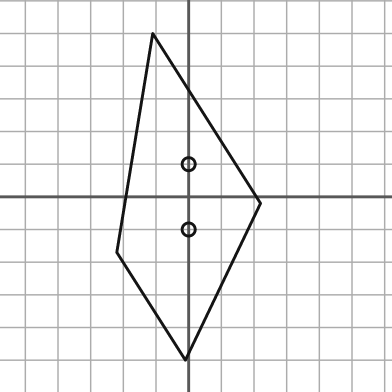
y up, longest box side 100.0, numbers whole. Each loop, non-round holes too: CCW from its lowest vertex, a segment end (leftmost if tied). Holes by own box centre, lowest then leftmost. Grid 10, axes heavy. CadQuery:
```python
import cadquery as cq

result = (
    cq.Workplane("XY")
    .moveTo(-1.0, -50.0)
    .lineTo(22.0, -2.0)
    .lineTo(-11.0, 50.0)
    .lineTo(-22.0, -17.0)
    .close()
    .moveTo(0.0, -10.0)
    .circle(2.0)
    .moveTo(0.0, 10.0)
    .circle(2.0)
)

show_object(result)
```